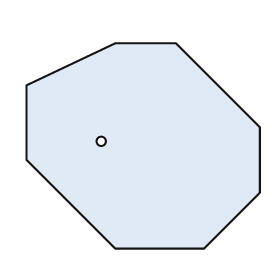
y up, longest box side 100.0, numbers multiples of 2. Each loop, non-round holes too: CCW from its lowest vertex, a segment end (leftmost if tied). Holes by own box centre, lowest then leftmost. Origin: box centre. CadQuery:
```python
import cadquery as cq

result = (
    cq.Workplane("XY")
    .moveTo(-12.0, -44.0)
    .lineTo(26.0, -44.0)
    .lineTo(50.0, -20.0)
    .lineTo(50.0, 8.0)
    .lineTo(14.0, 44.0)
    .lineTo(-12.0, 44.0)
    .lineTo(-50.0, 26.0)
    .lineTo(-50.0, -6.0)
    .close()
    .moveTo(-18.0, 2.0)
    .circle(2.0)
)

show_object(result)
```